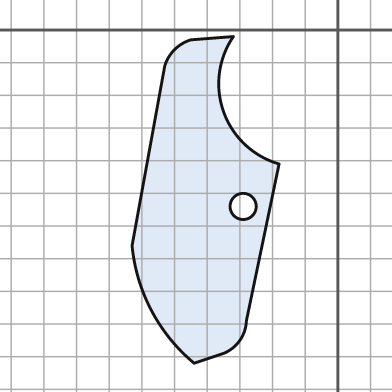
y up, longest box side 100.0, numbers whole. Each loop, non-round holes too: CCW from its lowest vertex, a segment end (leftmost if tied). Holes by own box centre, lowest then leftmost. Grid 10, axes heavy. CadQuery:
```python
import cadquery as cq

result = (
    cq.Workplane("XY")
    .moveTo(-44.0, -102.0)
    .lineTo(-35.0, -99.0)
    .threePointArc((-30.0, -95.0), (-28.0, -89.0))
    .lineTo(-18.0, -41.0)
    .threePointArc((-35.0, -25.0), (-32.0, -2.0))
    .lineTo(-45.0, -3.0)
    .threePointArc((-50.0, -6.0), (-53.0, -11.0))
    .lineTo(-63.0, -66.0)
    .threePointArc((-57.0, -86.0), (-44.0, -102.0))
    .close()
    .moveTo(-29.0, -54.0)
    .circle(4.0)
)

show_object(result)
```